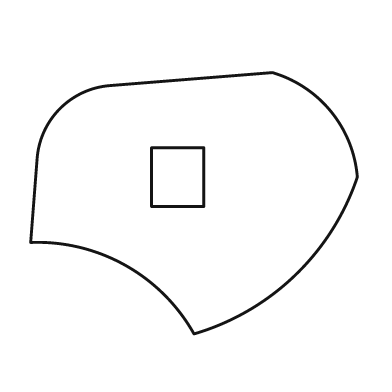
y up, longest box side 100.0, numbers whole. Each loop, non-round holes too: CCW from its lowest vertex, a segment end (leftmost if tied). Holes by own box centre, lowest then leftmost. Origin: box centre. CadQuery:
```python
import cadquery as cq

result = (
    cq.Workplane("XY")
    .moveTo(0.0, -40.0)
    .threePointArc((31.0, -22.0), (50.0, 8.0))
    .threePointArc((42.0, 28.0), (24.0, 40.0))
    .lineTo(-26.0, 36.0)
    .threePointArc((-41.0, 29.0), (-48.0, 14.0))
    .lineTo(-50.0, -12.0)
    .threePointArc((-21.0, -19.0), (0.0, -40.0))
    .close()
    .moveTo(-13.0, -1.0)
    .lineTo(3.0, -1.0)
    .lineTo(3.0, 17.0)
    .lineTo(-13.0, 17.0)
    .close()
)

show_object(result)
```